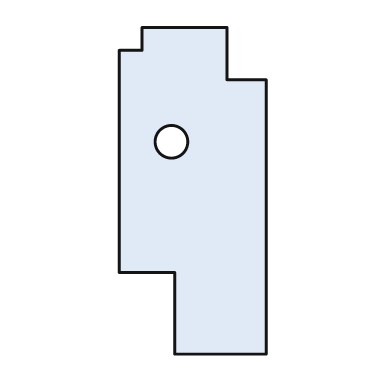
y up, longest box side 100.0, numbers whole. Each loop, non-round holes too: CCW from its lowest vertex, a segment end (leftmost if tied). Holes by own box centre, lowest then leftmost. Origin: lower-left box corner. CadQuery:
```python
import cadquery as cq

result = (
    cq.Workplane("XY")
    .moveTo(17.0, 0.0)
    .lineTo(45.0, 0.0)
    .lineTo(45.0, 84.0)
    .lineTo(33.0, 84.0)
    .lineTo(33.0, 100.0)
    .lineTo(7.0, 100.0)
    .lineTo(7.0, 93.0)
    .lineTo(0.0, 93.0)
    .lineTo(0.0, 25.0)
    .lineTo(17.0, 25.0)
    .close()
    .moveTo(16.0, 65.0)
    .circle(5.0)
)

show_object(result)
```